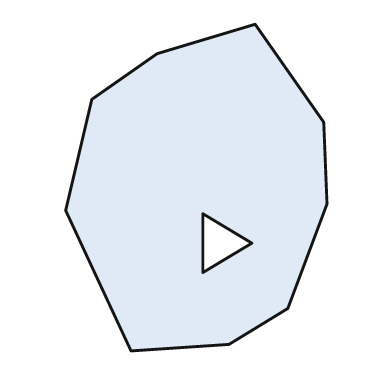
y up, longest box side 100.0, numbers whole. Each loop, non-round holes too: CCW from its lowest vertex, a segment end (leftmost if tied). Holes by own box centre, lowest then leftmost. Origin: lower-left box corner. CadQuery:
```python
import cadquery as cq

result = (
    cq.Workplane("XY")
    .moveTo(20.0, 0.0)
    .lineTo(50.0, 2.0)
    .lineTo(68.0, 13.0)
    .lineTo(80.0, 45.0)
    .lineTo(79.0, 70.0)
    .lineTo(58.0, 100.0)
    .lineTo(28.0, 91.0)
    .lineTo(8.0, 77.0)
    .lineTo(0.0, 43.0)
    .close()
    .moveTo(42.0, 24.0)
    .lineTo(57.0, 33.0)
    .lineTo(42.0, 42.0)
    .close()
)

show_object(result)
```